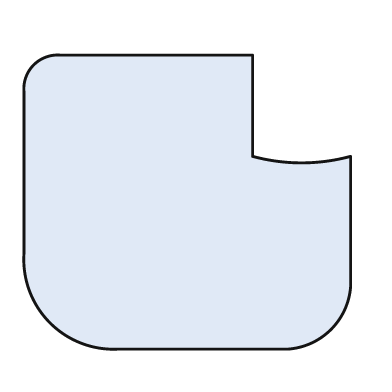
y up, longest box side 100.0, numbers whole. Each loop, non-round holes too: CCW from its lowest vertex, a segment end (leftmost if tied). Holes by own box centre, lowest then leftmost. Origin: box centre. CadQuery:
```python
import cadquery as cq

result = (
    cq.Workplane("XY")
    .moveTo(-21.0, -45.0)
    .lineTo(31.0, -45.0)
    .threePointArc((44.0, -39.0), (50.0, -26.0))
    .lineTo(50.0, 14.0)
    .threePointArc((35.0, 12.0), (20.0, 14.0))
    .lineTo(20.0, 45.0)
    .lineTo(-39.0, 45.0)
    .threePointArc((-47.0, 42.0), (-50.0, 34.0))
    .lineTo(-50.0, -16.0)
    .threePointArc((-42.0, -37.0), (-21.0, -45.0))
    .close()
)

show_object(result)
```